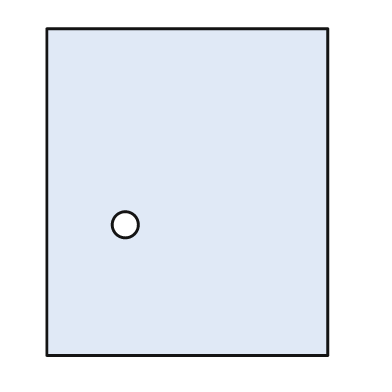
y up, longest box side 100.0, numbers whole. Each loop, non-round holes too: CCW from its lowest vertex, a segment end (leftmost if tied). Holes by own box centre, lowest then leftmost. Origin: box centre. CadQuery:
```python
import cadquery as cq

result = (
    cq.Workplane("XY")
    .moveTo(-43.0, -50.0)
    .lineTo(43.0, -50.0)
    .lineTo(43.0, 50.0)
    .lineTo(-43.0, 50.0)
    .close()
    .moveTo(-19.0, -10.0)
    .circle(4.0)
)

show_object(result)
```